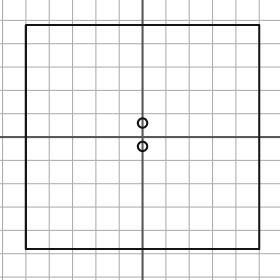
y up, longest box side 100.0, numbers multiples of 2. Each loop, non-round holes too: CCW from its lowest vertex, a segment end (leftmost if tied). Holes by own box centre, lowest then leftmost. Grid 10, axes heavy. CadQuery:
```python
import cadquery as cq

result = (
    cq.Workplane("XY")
    .moveTo(-50.0, -48.0)
    .lineTo(50.0, -48.0)
    .lineTo(50.0, 48.0)
    .lineTo(-50.0, 48.0)
    .close()
    .moveTo(0.0, -4.0)
    .circle(2.0)
    .moveTo(0.0, 6.0)
    .circle(2.0)
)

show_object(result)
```